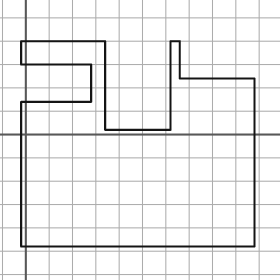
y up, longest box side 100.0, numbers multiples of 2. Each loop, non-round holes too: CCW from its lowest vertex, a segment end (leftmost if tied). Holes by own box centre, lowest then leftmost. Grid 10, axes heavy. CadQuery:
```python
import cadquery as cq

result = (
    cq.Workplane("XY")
    .moveTo(-2.0, -48.0)
    .lineTo(98.0, -48.0)
    .lineTo(98.0, 24.0)
    .lineTo(66.0, 24.0)
    .lineTo(66.0, 40.0)
    .lineTo(62.0, 40.0)
    .lineTo(62.0, 2.0)
    .lineTo(34.0, 2.0)
    .lineTo(34.0, 40.0)
    .lineTo(-2.0, 40.0)
    .lineTo(-2.0, 30.0)
    .lineTo(28.0, 30.0)
    .lineTo(28.0, 14.0)
    .lineTo(-2.0, 14.0)
    .close()
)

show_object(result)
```